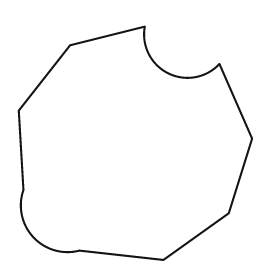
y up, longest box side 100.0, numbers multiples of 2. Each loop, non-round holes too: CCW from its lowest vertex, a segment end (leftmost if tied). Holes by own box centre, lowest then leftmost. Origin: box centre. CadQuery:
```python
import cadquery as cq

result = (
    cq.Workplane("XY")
    .moveTo(12.0, -50.0)
    .lineTo(40.0, -30.0)
    .lineTo(50.0, 2.0)
    .lineTo(36.0, 34.0)
    .threePointArc((14.0, 30.0), (4.0, 50.0))
    .lineTo(-28.0, 42.0)
    .lineTo(-50.0, 14.0)
    .lineTo(-48.0, -20.0)
    .threePointArc((-44.0, -40.0), (-24.0, -46.0))
    .close()
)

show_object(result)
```